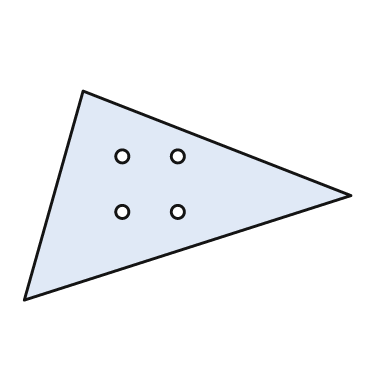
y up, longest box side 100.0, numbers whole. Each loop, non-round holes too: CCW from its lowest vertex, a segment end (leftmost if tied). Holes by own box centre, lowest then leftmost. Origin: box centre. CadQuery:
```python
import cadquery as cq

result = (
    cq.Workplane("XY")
    .moveTo(-50.0, -32.0)
    .lineTo(50.0, 0.0)
    .lineTo(-32.0, 32.0)
    .close()
    .moveTo(-20.0, -5.0)
    .circle(2.0)
    .moveTo(-3.0, -5.0)
    .circle(2.0)
    .moveTo(-20.0, 12.0)
    .circle(2.0)
    .moveTo(-3.0, 12.0)
    .circle(2.0)
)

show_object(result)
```